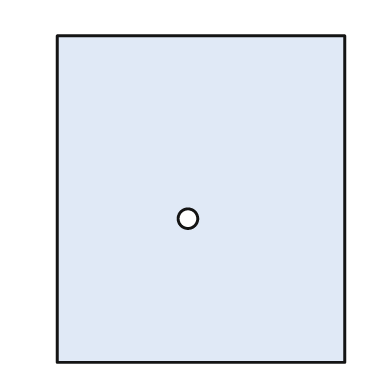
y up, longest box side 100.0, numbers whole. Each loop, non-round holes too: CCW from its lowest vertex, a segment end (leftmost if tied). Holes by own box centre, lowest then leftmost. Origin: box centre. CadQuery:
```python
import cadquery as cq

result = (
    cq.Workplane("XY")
    .moveTo(-44.0, -50.0)
    .lineTo(44.0, -50.0)
    .lineTo(44.0, 50.0)
    .lineTo(-44.0, 50.0)
    .close()
    .moveTo(-4.0, -6.0)
    .circle(3.0)
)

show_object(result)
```